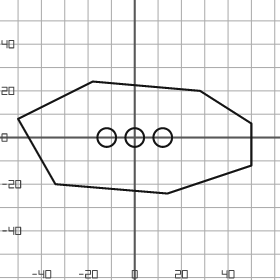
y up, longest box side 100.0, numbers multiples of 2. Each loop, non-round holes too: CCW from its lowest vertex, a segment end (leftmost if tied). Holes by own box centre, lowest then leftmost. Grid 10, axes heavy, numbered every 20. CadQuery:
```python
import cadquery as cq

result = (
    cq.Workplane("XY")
    .moveTo(14.0, -24.0)
    .lineTo(50.0, -12.0)
    .lineTo(50.0, 6.0)
    .lineTo(28.0, 20.0)
    .lineTo(-18.0, 24.0)
    .lineTo(-50.0, 8.0)
    .lineTo(-34.0, -20.0)
    .close()
    .moveTo(-12.0, 0.0)
    .circle(4.0)
    .moveTo(0.0, 0.0)
    .circle(4.0)
    .moveTo(12.0, 0.0)
    .circle(4.0)
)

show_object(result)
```